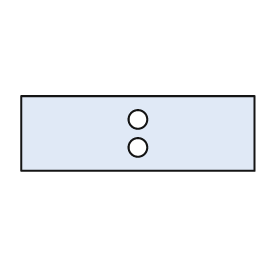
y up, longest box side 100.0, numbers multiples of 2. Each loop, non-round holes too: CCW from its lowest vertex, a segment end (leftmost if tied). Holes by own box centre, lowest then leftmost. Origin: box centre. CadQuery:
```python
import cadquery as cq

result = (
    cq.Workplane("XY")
    .moveTo(-50.0, -16.0)
    .lineTo(50.0, -16.0)
    .lineTo(50.0, 16.0)
    .lineTo(-50.0, 16.0)
    .close()
    .moveTo(0.0, -6.0)
    .circle(4.0)
    .moveTo(0.0, 6.0)
    .circle(4.0)
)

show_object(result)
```